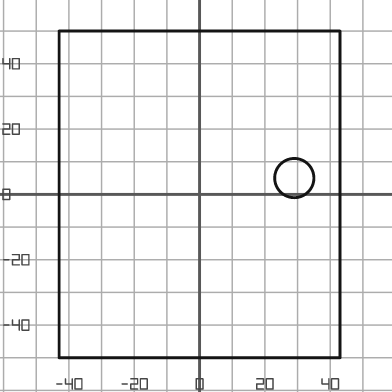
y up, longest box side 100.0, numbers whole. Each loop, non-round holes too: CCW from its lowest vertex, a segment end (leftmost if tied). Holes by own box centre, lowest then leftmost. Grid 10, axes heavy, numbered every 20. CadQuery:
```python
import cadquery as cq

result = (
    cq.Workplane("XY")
    .moveTo(-43.0, -50.0)
    .lineTo(43.0, -50.0)
    .lineTo(43.0, 50.0)
    .lineTo(-43.0, 50.0)
    .close()
    .moveTo(29.0, 5.0)
    .circle(6.0)
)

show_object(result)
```